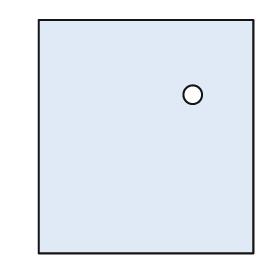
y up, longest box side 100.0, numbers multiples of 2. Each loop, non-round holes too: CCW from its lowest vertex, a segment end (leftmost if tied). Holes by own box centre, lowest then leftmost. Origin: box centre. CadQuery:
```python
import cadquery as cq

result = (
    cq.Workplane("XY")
    .moveTo(-46.0, -50.0)
    .lineTo(46.0, -50.0)
    .lineTo(46.0, 50.0)
    .lineTo(-46.0, 50.0)
    .close()
    .moveTo(20.0, 18.0)
    .circle(4.0)
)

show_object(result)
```